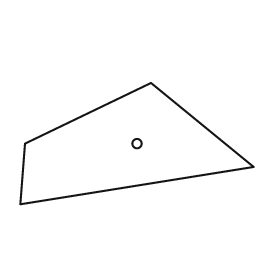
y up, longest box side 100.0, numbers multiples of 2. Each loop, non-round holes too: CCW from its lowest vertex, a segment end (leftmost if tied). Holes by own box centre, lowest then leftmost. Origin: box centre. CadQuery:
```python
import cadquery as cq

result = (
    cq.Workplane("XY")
    .moveTo(-50.0, -26.0)
    .lineTo(50.0, -10.0)
    .lineTo(6.0, 26.0)
    .lineTo(-48.0, 0.0)
    .close()
    .moveTo(0.0, 0.0)
    .circle(2.0)
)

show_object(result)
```